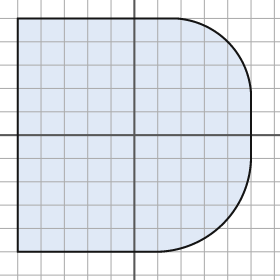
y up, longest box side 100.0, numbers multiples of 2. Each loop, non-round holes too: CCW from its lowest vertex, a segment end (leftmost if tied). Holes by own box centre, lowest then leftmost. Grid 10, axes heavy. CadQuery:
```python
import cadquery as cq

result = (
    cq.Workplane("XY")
    .moveTo(-50.0, -50.0)
    .lineTo(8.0, -50.0)
    .threePointArc((38.0, -38.0), (50.0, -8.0))
    .lineTo(50.0, 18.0)
    .threePointArc((40.0, 40.0), (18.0, 50.0))
    .lineTo(-50.0, 50.0)
    .close()
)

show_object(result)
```